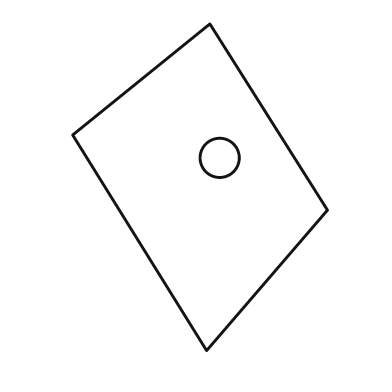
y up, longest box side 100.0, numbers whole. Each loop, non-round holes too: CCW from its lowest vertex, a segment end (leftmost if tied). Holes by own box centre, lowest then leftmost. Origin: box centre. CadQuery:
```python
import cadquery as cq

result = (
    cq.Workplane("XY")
    .moveTo(2.0, -50.0)
    .lineTo(39.0, -7.0)
    .lineTo(3.0, 50.0)
    .lineTo(-39.0, 16.0)
    .close()
    .moveTo(6.0, 9.0)
    .circle(6.0)
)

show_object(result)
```